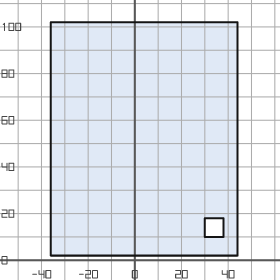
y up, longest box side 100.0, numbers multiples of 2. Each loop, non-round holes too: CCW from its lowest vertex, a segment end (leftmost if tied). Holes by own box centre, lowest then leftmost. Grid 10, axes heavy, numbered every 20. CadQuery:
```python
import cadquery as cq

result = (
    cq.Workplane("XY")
    .moveTo(-36.0, 2.0)
    .lineTo(44.0, 2.0)
    .lineTo(44.0, 102.0)
    .lineTo(-36.0, 102.0)
    .close()
    .moveTo(30.0, 10.0)
    .lineTo(38.0, 10.0)
    .lineTo(38.0, 18.0)
    .lineTo(30.0, 18.0)
    .close()
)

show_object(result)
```